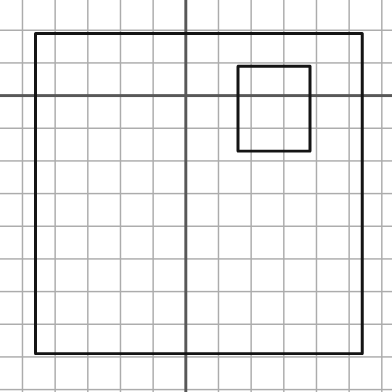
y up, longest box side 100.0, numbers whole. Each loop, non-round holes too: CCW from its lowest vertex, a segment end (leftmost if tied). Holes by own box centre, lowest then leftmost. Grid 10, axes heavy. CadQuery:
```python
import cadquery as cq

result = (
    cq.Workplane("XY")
    .moveTo(-46.0, -79.0)
    .lineTo(54.0, -79.0)
    .lineTo(54.0, 19.0)
    .lineTo(-46.0, 19.0)
    .close()
    .moveTo(16.0, -17.0)
    .lineTo(38.0, -17.0)
    .lineTo(38.0, 9.0)
    .lineTo(16.0, 9.0)
    .close()
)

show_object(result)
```